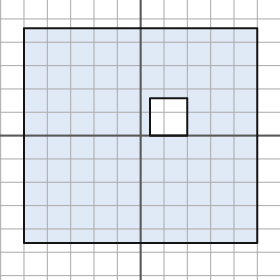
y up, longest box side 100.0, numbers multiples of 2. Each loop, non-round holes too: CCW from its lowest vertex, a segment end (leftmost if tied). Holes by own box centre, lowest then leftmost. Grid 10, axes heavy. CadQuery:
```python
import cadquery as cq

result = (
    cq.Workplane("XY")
    .moveTo(-50.0, -46.0)
    .lineTo(50.0, -46.0)
    .lineTo(50.0, 46.0)
    .lineTo(-50.0, 46.0)
    .close()
    .moveTo(4.0, 0.0)
    .lineTo(20.0, 0.0)
    .lineTo(20.0, 16.0)
    .lineTo(4.0, 16.0)
    .close()
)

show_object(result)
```